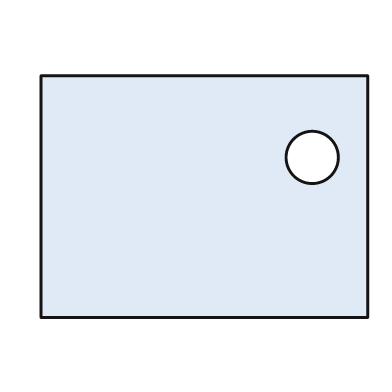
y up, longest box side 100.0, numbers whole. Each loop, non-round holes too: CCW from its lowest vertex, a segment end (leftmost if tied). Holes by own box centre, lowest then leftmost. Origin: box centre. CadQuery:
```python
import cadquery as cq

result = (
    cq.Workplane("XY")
    .moveTo(-50.0, -37.0)
    .lineTo(50.0, -37.0)
    .lineTo(50.0, 37.0)
    .lineTo(-50.0, 37.0)
    .close()
    .moveTo(33.0, 12.0)
    .circle(8.0)
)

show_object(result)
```